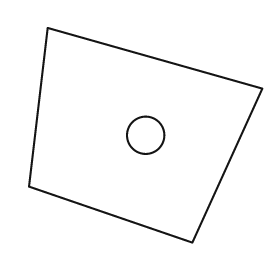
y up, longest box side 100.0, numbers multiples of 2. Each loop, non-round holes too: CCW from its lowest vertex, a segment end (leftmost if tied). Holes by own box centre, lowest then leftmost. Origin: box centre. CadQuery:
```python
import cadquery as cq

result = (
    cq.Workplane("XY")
    .moveTo(20.0, -46.0)
    .lineTo(50.0, 20.0)
    .lineTo(-42.0, 46.0)
    .lineTo(-50.0, -22.0)
    .close()
    .moveTo(0.0, 0.0)
    .circle(8.0)
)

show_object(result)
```